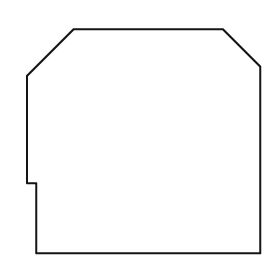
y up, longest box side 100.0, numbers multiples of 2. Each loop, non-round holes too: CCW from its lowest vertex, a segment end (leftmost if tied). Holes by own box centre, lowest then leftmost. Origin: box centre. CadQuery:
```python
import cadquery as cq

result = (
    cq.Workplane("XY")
    .moveTo(-46.0, -48.0)
    .lineTo(50.0, -48.0)
    .lineTo(50.0, 32.0)
    .lineTo(34.0, 48.0)
    .lineTo(-30.0, 48.0)
    .lineTo(-50.0, 28.0)
    .lineTo(-50.0, -18.0)
    .lineTo(-46.0, -18.0)
    .close()
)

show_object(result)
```